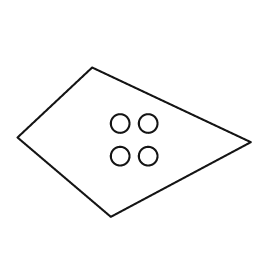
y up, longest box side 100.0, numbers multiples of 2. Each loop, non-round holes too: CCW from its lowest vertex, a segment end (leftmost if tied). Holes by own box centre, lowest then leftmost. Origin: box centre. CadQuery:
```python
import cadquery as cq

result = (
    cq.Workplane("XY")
    .moveTo(-10.0, -32.0)
    .lineTo(50.0, 0.0)
    .lineTo(-18.0, 32.0)
    .lineTo(-50.0, 2.0)
    .close()
    .moveTo(-6.0, -6.0)
    .circle(4.0)
    .moveTo(6.0, -6.0)
    .circle(4.0)
    .moveTo(-6.0, 8.0)
    .circle(4.0)
    .moveTo(6.0, 8.0)
    .circle(4.0)
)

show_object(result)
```